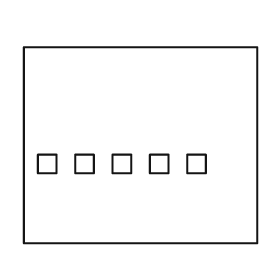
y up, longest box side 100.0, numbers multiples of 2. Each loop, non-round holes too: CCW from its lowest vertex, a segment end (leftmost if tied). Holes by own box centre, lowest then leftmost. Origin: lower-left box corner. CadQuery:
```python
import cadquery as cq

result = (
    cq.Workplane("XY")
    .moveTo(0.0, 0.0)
    .lineTo(100.0, 0.0)
    .lineTo(100.0, 84.0)
    .lineTo(0.0, 84.0)
    .close()
    .moveTo(6.0, 30.0)
    .lineTo(14.0, 30.0)
    .lineTo(14.0, 38.0)
    .lineTo(6.0, 38.0)
    .close()
    .moveTo(22.0, 30.0)
    .lineTo(30.0, 30.0)
    .lineTo(30.0, 38.0)
    .lineTo(22.0, 38.0)
    .close()
    .moveTo(38.0, 30.0)
    .lineTo(46.0, 30.0)
    .lineTo(46.0, 38.0)
    .lineTo(38.0, 38.0)
    .close()
    .moveTo(54.0, 30.0)
    .lineTo(62.0, 30.0)
    .lineTo(62.0, 38.0)
    .lineTo(54.0, 38.0)
    .close()
    .moveTo(70.0, 30.0)
    .lineTo(78.0, 30.0)
    .lineTo(78.0, 38.0)
    .lineTo(70.0, 38.0)
    .close()
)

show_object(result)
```